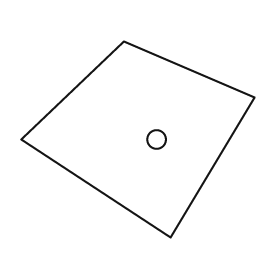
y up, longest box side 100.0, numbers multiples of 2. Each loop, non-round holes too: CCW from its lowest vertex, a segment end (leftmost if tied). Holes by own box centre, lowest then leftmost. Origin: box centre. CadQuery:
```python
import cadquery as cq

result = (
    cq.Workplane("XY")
    .moveTo(14.0, -42.0)
    .lineTo(50.0, 18.0)
    .lineTo(-6.0, 42.0)
    .lineTo(-50.0, 0.0)
    .close()
    .moveTo(8.0, 0.0)
    .circle(4.0)
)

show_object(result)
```